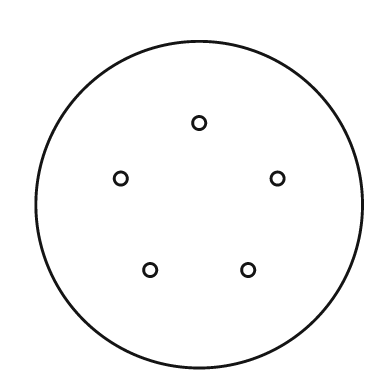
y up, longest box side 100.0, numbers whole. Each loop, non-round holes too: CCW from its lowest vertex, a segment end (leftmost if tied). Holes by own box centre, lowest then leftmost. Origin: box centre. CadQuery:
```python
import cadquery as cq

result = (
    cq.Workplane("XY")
    .moveTo(0.0, 0.0)
    .circle(50.0)
    .moveTo(-15.0, -20.0)
    .circle(2.0)
    .moveTo(15.0, -20.0)
    .circle(2.0)
    .moveTo(-24.0, 8.0)
    .circle(2.0)
    .moveTo(24.0, 8.0)
    .circle(2.0)
    .moveTo(0.0, 25.0)
    .circle(2.0)
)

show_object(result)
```